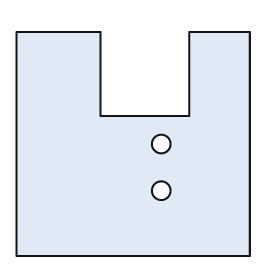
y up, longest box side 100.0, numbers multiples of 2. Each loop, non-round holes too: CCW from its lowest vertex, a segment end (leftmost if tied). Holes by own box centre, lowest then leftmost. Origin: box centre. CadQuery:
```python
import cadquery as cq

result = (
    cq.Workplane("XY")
    .moveTo(-50.0, -48.0)
    .lineTo(50.0, -48.0)
    .lineTo(50.0, 48.0)
    .lineTo(24.0, 48.0)
    .lineTo(24.0, 12.0)
    .lineTo(-14.0, 12.0)
    .lineTo(-14.0, 48.0)
    .lineTo(-50.0, 48.0)
    .close()
    .moveTo(12.0, -20.0)
    .circle(4.0)
    .moveTo(12.0, 0.0)
    .circle(4.0)
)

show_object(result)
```